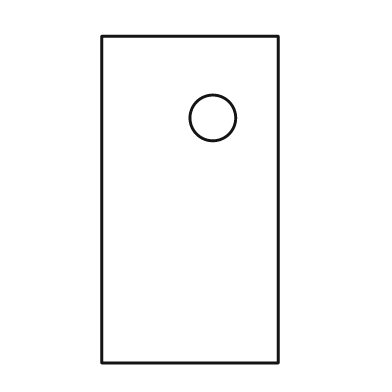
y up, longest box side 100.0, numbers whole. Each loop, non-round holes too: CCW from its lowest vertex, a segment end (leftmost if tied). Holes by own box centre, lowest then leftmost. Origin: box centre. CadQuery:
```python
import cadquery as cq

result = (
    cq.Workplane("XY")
    .moveTo(-27.0, -50.0)
    .lineTo(27.0, -50.0)
    .lineTo(27.0, 50.0)
    .lineTo(-27.0, 50.0)
    .close()
    .moveTo(7.0, 25.0)
    .circle(7.0)
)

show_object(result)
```